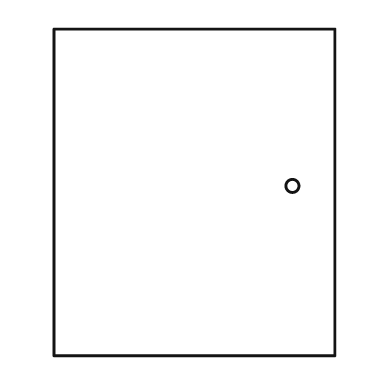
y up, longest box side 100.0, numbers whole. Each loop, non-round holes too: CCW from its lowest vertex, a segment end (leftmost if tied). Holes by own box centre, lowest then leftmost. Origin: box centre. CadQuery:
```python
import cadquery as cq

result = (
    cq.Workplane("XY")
    .moveTo(-43.0, -50.0)
    .lineTo(43.0, -50.0)
    .lineTo(43.0, 50.0)
    .lineTo(-43.0, 50.0)
    .close()
    .moveTo(30.0, 2.0)
    .circle(2.0)
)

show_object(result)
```